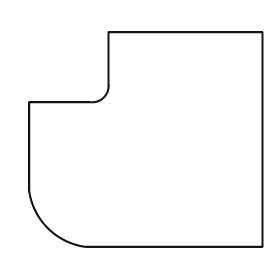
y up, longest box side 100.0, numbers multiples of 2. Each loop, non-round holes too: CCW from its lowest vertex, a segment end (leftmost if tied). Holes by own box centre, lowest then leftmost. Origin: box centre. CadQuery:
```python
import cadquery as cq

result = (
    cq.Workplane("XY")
    .moveTo(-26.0, -46.0)
    .lineTo(50.0, -46.0)
    .lineTo(50.0, 46.0)
    .lineTo(-16.0, 46.0)
    .lineTo(-16.0, 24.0)
    .threePointArc((-18.0, 18.0), (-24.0, 16.0))
    .lineTo(-50.0, 16.0)
    .lineTo(-50.0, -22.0)
    .threePointArc((-42.0, -38.0), (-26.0, -46.0))
    .close()
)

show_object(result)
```